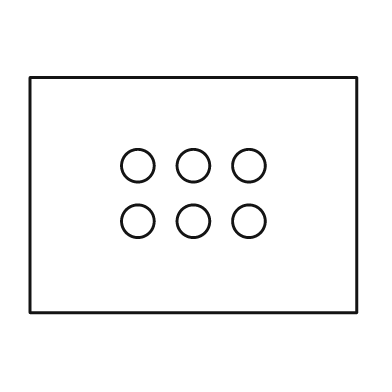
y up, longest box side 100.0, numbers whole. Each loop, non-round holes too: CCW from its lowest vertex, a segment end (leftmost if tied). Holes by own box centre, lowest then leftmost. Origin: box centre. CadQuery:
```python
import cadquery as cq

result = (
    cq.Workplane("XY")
    .moveTo(-50.0, -36.0)
    .lineTo(50.0, -36.0)
    .lineTo(50.0, 36.0)
    .lineTo(-50.0, 36.0)
    .close()
    .moveTo(-17.0, -8.0)
    .circle(5.0)
    .moveTo(0.0, -8.0)
    .circle(5.0)
    .moveTo(17.0, -8.0)
    .circle(5.0)
    .moveTo(-17.0, 9.0)
    .circle(5.0)
    .moveTo(0.0, 9.0)
    .circle(5.0)
    .moveTo(17.0, 9.0)
    .circle(5.0)
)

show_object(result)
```